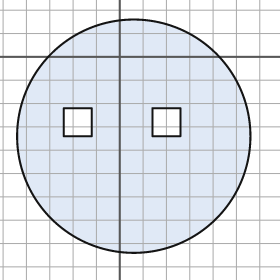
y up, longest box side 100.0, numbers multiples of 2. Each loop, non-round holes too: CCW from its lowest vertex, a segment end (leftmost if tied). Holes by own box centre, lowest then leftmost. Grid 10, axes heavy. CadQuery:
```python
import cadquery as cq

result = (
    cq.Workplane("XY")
    .moveTo(6.0, -34.0)
    .circle(50.0)
    .moveTo(-24.0, -34.0)
    .lineTo(-12.0, -34.0)
    .lineTo(-12.0, -22.0)
    .lineTo(-24.0, -22.0)
    .close()
    .moveTo(14.0, -34.0)
    .lineTo(26.0, -34.0)
    .lineTo(26.0, -22.0)
    .lineTo(14.0, -22.0)
    .close()
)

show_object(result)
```